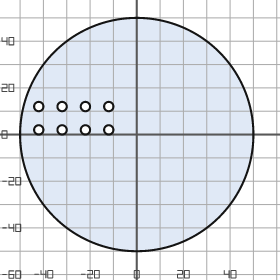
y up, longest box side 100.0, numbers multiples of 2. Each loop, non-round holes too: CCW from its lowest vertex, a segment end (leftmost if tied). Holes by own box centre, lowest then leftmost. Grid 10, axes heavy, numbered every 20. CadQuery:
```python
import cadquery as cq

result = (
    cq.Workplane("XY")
    .moveTo(0.0, 0.0)
    .circle(50.0)
    .moveTo(-42.0, 2.0)
    .circle(2.0)
    .moveTo(-32.0, 2.0)
    .circle(2.0)
    .moveTo(-22.0, 2.0)
    .circle(2.0)
    .moveTo(-12.0, 2.0)
    .circle(2.0)
    .moveTo(-42.0, 12.0)
    .circle(2.0)
    .moveTo(-32.0, 12.0)
    .circle(2.0)
    .moveTo(-22.0, 12.0)
    .circle(2.0)
    .moveTo(-12.0, 12.0)
    .circle(2.0)
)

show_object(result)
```